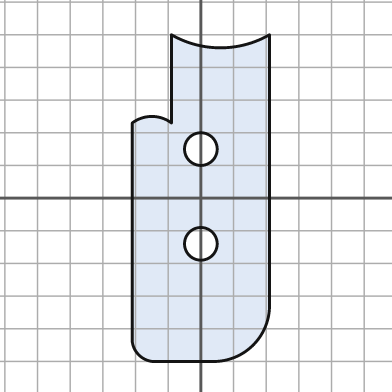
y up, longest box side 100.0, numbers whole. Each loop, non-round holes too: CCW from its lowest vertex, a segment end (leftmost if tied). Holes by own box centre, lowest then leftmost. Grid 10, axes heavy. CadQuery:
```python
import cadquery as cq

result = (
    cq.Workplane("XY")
    .moveTo(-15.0, -50.0)
    .lineTo(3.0, -50.0)
    .threePointArc((16.0, -45.0), (21.0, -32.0))
    .lineTo(21.0, 50.0)
    .threePointArc((6.0, 46.0), (-9.0, 50.0))
    .lineTo(-9.0, 23.0)
    .threePointArc((-15.0, 25.0), (-21.0, 23.0))
    .lineTo(-21.0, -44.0)
    .threePointArc((-19.0, -48.0), (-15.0, -50.0))
    .close()
    .moveTo(0.0, -14.0)
    .circle(5.0)
    .moveTo(0.0, 15.0)
    .circle(5.0)
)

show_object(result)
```